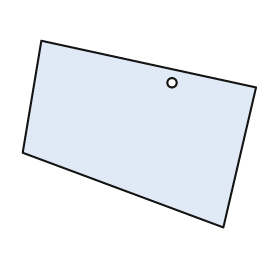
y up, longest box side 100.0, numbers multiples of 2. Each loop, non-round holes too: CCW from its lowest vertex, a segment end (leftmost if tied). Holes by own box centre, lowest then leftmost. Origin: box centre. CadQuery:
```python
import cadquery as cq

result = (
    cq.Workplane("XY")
    .moveTo(36.0, -40.0)
    .lineTo(50.0, 20.0)
    .lineTo(-42.0, 40.0)
    .lineTo(-50.0, -8.0)
    .close()
    .moveTo(14.0, 22.0)
    .circle(2.0)
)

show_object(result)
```